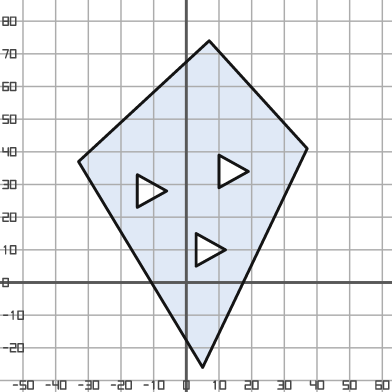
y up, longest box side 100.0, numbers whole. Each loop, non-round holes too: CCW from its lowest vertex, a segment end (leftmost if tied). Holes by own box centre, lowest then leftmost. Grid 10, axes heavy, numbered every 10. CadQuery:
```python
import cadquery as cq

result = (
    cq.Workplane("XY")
    .moveTo(5.0, -26.0)
    .lineTo(37.0, 41.0)
    .lineTo(7.0, 74.0)
    .lineTo(-33.0, 37.0)
    .close()
    .moveTo(3.0, 5.0)
    .lineTo(12.0, 10.0)
    .lineTo(3.0, 15.0)
    .close()
    .moveTo(-15.0, 23.0)
    .lineTo(-6.0, 28.0)
    .lineTo(-15.0, 33.0)
    .close()
    .moveTo(10.0, 29.0)
    .lineTo(19.0, 34.0)
    .lineTo(10.0, 39.0)
    .close()
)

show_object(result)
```